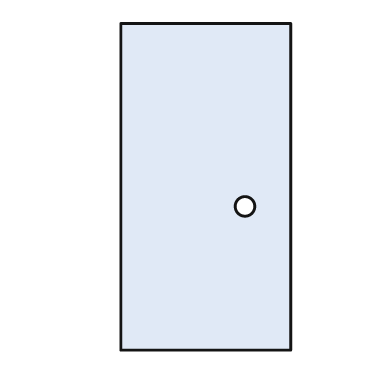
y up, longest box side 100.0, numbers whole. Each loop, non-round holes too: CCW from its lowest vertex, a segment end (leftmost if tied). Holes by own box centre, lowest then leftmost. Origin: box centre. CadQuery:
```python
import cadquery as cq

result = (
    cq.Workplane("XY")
    .moveTo(-26.0, -50.0)
    .lineTo(26.0, -50.0)
    .lineTo(26.0, 50.0)
    .lineTo(-26.0, 50.0)
    .close()
    .moveTo(12.0, -6.0)
    .circle(3.0)
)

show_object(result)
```